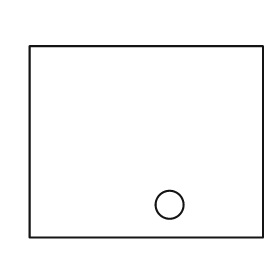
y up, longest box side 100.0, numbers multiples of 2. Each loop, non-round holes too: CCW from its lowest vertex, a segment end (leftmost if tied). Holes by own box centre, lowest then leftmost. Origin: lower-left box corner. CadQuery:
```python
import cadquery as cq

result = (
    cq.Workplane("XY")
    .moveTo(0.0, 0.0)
    .lineTo(100.0, 0.0)
    .lineTo(100.0, 82.0)
    .lineTo(0.0, 82.0)
    .close()
    .moveTo(60.0, 14.0)
    .circle(6.0)
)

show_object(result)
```